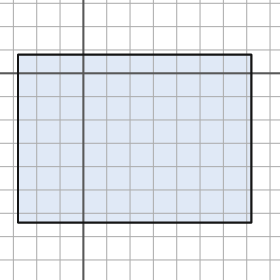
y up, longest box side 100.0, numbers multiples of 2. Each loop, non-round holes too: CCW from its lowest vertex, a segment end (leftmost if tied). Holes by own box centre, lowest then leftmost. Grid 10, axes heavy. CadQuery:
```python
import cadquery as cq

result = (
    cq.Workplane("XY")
    .moveTo(-28.0, -64.0)
    .lineTo(72.0, -64.0)
    .lineTo(72.0, 8.0)
    .lineTo(-28.0, 8.0)
    .close()
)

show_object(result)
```